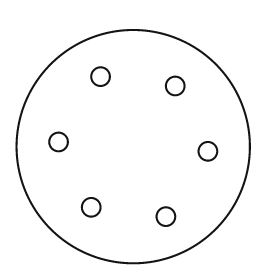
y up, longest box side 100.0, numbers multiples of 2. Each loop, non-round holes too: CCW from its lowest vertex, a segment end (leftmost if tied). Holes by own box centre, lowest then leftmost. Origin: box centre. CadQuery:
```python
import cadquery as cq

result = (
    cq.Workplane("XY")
    .moveTo(0.0, 0.0)
    .circle(50.0)
    .moveTo(14.0, -30.0)
    .circle(4.0)
    .moveTo(-18.0, -26.0)
    .circle(4.0)
    .moveTo(32.0, -2.0)
    .circle(4.0)
    .moveTo(-32.0, 2.0)
    .circle(4.0)
    .moveTo(18.0, 26.0)
    .circle(4.0)
    .moveTo(-14.0, 30.0)
    .circle(4.0)
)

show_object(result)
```